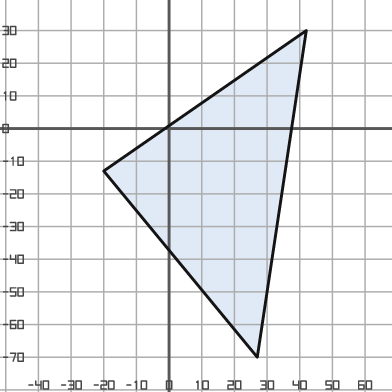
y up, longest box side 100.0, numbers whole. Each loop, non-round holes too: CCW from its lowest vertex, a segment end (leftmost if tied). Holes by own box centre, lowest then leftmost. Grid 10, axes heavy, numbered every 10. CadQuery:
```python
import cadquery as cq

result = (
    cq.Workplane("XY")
    .moveTo(27.0, -70.0)
    .lineTo(42.0, 30.0)
    .lineTo(-20.0, -13.0)
    .close()
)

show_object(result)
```